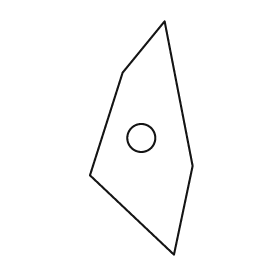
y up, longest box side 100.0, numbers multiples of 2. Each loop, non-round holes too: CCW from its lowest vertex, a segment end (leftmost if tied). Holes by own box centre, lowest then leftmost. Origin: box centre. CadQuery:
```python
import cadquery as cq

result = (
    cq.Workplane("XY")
    .moveTo(14.0, -50.0)
    .lineTo(22.0, -12.0)
    .lineTo(10.0, 50.0)
    .lineTo(-8.0, 28.0)
    .lineTo(-22.0, -16.0)
    .close()
    .moveTo(0.0, 0.0)
    .circle(6.0)
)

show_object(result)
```